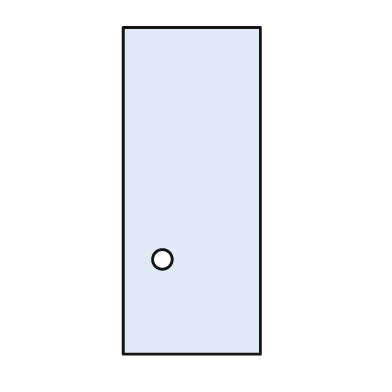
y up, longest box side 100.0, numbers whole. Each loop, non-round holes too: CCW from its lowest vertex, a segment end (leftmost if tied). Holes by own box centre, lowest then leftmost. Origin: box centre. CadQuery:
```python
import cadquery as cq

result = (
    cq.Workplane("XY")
    .moveTo(-21.0, -50.0)
    .lineTo(21.0, -50.0)
    .lineTo(21.0, 50.0)
    .lineTo(-21.0, 50.0)
    .close()
    .moveTo(-9.0, -21.0)
    .circle(3.0)
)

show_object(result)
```